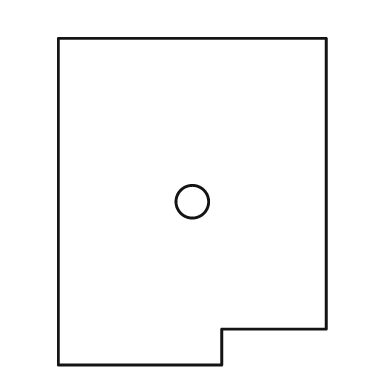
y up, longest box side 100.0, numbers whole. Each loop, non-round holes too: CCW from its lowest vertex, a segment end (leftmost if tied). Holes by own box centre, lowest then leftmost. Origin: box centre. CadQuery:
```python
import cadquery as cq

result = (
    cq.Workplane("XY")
    .moveTo(-41.0, -50.0)
    .lineTo(9.0, -50.0)
    .lineTo(9.0, -39.0)
    .lineTo(41.0, -39.0)
    .lineTo(41.0, 50.0)
    .lineTo(-41.0, 50.0)
    .close()
    .moveTo(0.0, 0.0)
    .circle(5.0)
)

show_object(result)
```